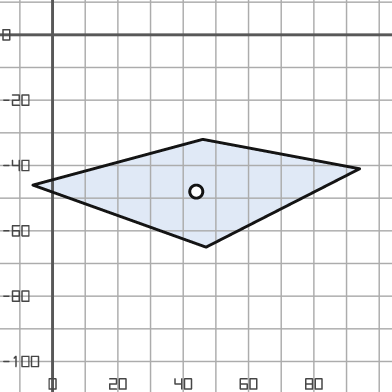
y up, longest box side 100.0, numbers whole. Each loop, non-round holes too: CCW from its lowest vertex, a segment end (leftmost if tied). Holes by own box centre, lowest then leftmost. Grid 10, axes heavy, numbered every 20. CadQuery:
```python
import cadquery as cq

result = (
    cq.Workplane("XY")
    .moveTo(47.0, -65.0)
    .lineTo(94.0, -41.0)
    .lineTo(46.0, -32.0)
    .lineTo(-6.0, -46.0)
    .close()
    .moveTo(44.0, -48.0)
    .circle(2.0)
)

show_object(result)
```